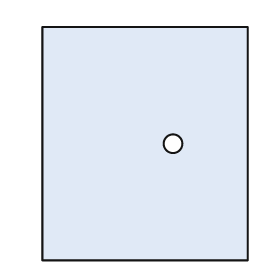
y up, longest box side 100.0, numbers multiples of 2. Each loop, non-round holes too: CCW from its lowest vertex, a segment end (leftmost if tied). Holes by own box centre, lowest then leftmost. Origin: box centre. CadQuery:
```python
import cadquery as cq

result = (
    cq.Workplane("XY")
    .moveTo(-44.0, -50.0)
    .lineTo(44.0, -50.0)
    .lineTo(44.0, 50.0)
    .lineTo(-44.0, 50.0)
    .close()
    .moveTo(12.0, 0.0)
    .circle(4.0)
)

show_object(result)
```